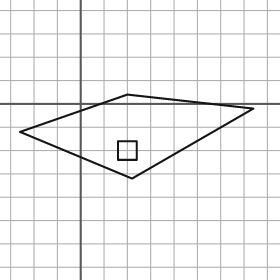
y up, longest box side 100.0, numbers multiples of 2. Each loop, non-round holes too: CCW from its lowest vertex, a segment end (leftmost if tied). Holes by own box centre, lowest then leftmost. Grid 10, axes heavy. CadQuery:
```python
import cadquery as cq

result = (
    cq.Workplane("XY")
    .moveTo(22.0, -32.0)
    .lineTo(74.0, -2.0)
    .lineTo(20.0, 4.0)
    .lineTo(-26.0, -12.0)
    .close()
    .moveTo(16.0, -24.0)
    .lineTo(24.0, -24.0)
    .lineTo(24.0, -16.0)
    .lineTo(16.0, -16.0)
    .close()
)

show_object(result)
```